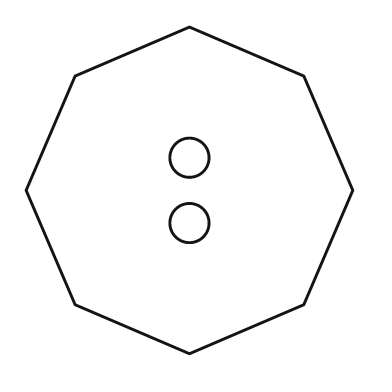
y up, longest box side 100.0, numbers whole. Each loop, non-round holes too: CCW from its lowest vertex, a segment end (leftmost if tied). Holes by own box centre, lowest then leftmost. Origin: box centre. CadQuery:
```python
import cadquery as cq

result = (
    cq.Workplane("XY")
    .moveTo(0.0, -50.0)
    .lineTo(35.0, -35.0)
    .lineTo(50.0, 0.0)
    .lineTo(35.0, 35.0)
    .lineTo(0.0, 50.0)
    .lineTo(-35.0, 35.0)
    .lineTo(-50.0, 0.0)
    .lineTo(-35.0, -35.0)
    .close()
    .moveTo(0.0, -10.0)
    .circle(6.0)
    .moveTo(0.0, 10.0)
    .circle(6.0)
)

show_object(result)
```